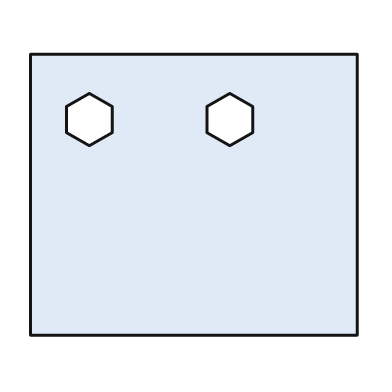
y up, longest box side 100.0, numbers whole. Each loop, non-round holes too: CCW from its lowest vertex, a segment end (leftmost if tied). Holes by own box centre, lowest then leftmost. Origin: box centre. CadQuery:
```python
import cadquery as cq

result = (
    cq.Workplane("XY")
    .moveTo(-50.0, -43.0)
    .lineTo(50.0, -43.0)
    .lineTo(50.0, 43.0)
    .lineTo(-50.0, 43.0)
    .close()
    .moveTo(-32.0, 15.0)
    .lineTo(-25.0, 19.0)
    .lineTo(-25.0, 27.0)
    .lineTo(-32.0, 31.0)
    .lineTo(-39.0, 27.0)
    .lineTo(-39.0, 19.0)
    .close()
    .moveTo(11.0, 15.0)
    .lineTo(18.0, 19.0)
    .lineTo(18.0, 27.0)
    .lineTo(11.0, 31.0)
    .lineTo(4.0, 27.0)
    .lineTo(4.0, 19.0)
    .close()
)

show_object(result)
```